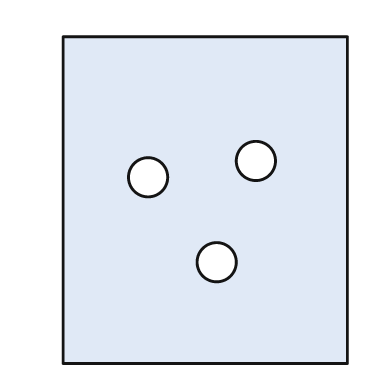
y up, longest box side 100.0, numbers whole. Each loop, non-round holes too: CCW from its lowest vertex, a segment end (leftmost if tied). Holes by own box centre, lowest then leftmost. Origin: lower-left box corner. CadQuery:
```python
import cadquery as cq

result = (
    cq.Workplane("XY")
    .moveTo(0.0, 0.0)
    .lineTo(87.0, 0.0)
    .lineTo(87.0, 100.0)
    .lineTo(0.0, 100.0)
    .close()
    .moveTo(47.0, 31.0)
    .circle(6.0)
    .moveTo(26.0, 57.0)
    .circle(6.0)
    .moveTo(59.0, 62.0)
    .circle(6.0)
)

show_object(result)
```